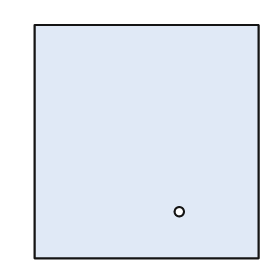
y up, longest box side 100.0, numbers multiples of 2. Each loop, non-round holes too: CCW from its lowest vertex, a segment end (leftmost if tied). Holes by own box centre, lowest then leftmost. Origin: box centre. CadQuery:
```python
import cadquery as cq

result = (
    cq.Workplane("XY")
    .moveTo(-48.0, -50.0)
    .lineTo(48.0, -50.0)
    .lineTo(48.0, 50.0)
    .lineTo(-48.0, 50.0)
    .close()
    .moveTo(14.0, -30.0)
    .circle(2.0)
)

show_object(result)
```